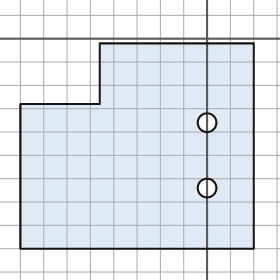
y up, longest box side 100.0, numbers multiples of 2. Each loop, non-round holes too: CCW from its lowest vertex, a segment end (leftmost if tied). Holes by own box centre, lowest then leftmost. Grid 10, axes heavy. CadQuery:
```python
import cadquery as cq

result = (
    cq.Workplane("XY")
    .moveTo(-80.0, -90.0)
    .lineTo(20.0, -90.0)
    .lineTo(20.0, -2.0)
    .lineTo(-46.0, -2.0)
    .lineTo(-46.0, -28.0)
    .lineTo(-80.0, -28.0)
    .close()
    .moveTo(0.0, -64.0)
    .circle(4.0)
    .moveTo(0.0, -36.0)
    .circle(4.0)
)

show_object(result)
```